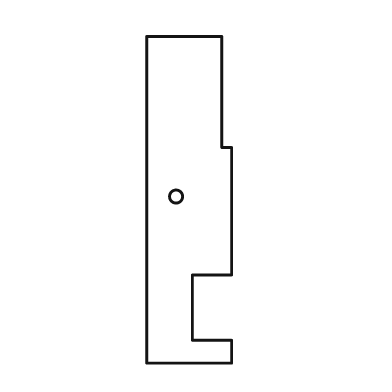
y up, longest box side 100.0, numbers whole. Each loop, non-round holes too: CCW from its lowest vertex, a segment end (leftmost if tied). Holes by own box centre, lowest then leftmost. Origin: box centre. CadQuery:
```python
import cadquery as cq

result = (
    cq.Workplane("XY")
    .moveTo(-13.0, -50.0)
    .lineTo(13.0, -50.0)
    .lineTo(13.0, -43.0)
    .lineTo(1.0, -43.0)
    .lineTo(1.0, -23.0)
    .lineTo(13.0, -23.0)
    .lineTo(13.0, 16.0)
    .lineTo(10.0, 16.0)
    .lineTo(10.0, 50.0)
    .lineTo(-13.0, 50.0)
    .close()
    .moveTo(-4.0, 1.0)
    .circle(2.0)
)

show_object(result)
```